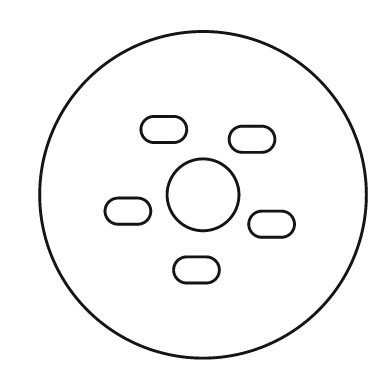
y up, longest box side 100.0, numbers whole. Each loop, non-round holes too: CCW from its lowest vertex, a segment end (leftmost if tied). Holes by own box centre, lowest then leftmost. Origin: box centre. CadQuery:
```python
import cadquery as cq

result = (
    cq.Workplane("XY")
    .moveTo(0.0, 0.0)
    .circle(50.0)
    .moveTo(-5.0, -27.0)
    .lineTo(1.0, -27.0)
    .threePointArc((5.0, -23.0), (1.0, -19.0))
    .lineTo(-5.0, -19.0)
    .threePointArc((-9.0, -23.0), (-5.0, -27.0))
    .close()
    .moveTo(18.0, -13.0)
    .lineTo(24.0, -13.0)
    .threePointArc((28.0, -9.0), (24.0, -5.0))
    .lineTo(18.0, -5.0)
    .threePointArc((14.0, -9.0), (18.0, -13.0))
    .close()
    .moveTo(-26.0, -9.0)
    .lineTo(-20.0, -9.0)
    .threePointArc((-16.0, -5.0), (-20.0, -1.0))
    .lineTo(-26.0, -1.0)
    .threePointArc((-30.0, -5.0), (-26.0, -9.0))
    .close()
    .moveTo(0.0, 0.0)
    .circle(11.0)
    .moveTo(12.0, 13.0)
    .lineTo(18.0, 13.0)
    .threePointArc((22.0, 17.0), (18.0, 21.0))
    .lineTo(12.0, 21.0)
    .threePointArc((8.0, 17.0), (12.0, 13.0))
    .close()
    .moveTo(-15.0, 16.0)
    .lineTo(-9.0, 16.0)
    .threePointArc((-5.0, 20.0), (-9.0, 24.0))
    .lineTo(-15.0, 24.0)
    .threePointArc((-19.0, 20.0), (-15.0, 16.0))
    .close()
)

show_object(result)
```